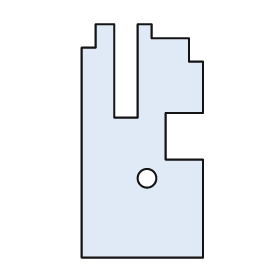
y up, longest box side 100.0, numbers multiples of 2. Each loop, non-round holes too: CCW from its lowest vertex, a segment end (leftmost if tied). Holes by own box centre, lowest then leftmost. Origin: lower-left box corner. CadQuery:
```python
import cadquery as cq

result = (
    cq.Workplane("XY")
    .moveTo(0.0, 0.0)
    .lineTo(52.0, 0.0)
    .lineTo(52.0, 42.0)
    .lineTo(36.0, 42.0)
    .lineTo(36.0, 62.0)
    .lineTo(52.0, 62.0)
    .lineTo(52.0, 84.0)
    .lineTo(46.0, 84.0)
    .lineTo(46.0, 94.0)
    .lineTo(30.0, 94.0)
    .lineTo(30.0, 100.0)
    .lineTo(24.0, 100.0)
    .lineTo(24.0, 60.0)
    .lineTo(14.0, 60.0)
    .lineTo(14.0, 100.0)
    .lineTo(6.0, 100.0)
    .lineTo(6.0, 90.0)
    .lineTo(0.0, 90.0)
    .close()
    .moveTo(28.0, 34.0)
    .circle(4.0)
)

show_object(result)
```